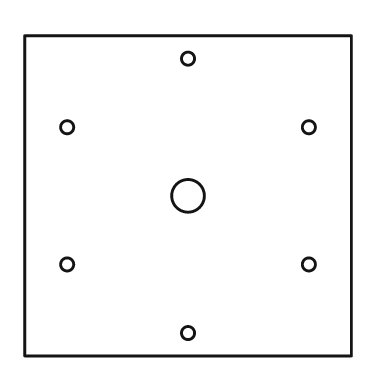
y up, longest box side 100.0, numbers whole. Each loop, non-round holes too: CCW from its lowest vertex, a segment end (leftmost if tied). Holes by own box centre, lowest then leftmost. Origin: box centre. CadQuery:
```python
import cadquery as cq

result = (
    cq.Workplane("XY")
    .moveTo(-50.0, -49.0)
    .lineTo(50.0, -49.0)
    .lineTo(50.0, 49.0)
    .lineTo(-50.0, 49.0)
    .close()
    .moveTo(0.0, -42.0)
    .circle(2.0)
    .moveTo(-37.0, -21.0)
    .circle(2.0)
    .moveTo(37.0, -21.0)
    .circle(2.0)
    .moveTo(0.0, 0.0)
    .circle(5.0)
    .moveTo(-37.0, 21.0)
    .circle(2.0)
    .moveTo(37.0, 21.0)
    .circle(2.0)
    .moveTo(0.0, 42.0)
    .circle(2.0)
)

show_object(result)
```